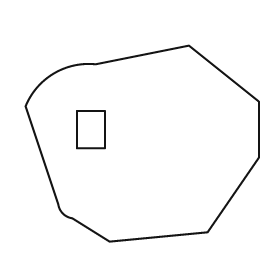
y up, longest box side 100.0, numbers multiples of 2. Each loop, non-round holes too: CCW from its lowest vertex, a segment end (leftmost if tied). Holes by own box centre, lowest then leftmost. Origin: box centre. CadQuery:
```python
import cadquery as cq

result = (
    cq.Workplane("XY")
    .moveTo(-14.0, -42.0)
    .lineTo(28.0, -38.0)
    .lineTo(50.0, -6.0)
    .lineTo(50.0, 18.0)
    .lineTo(20.0, 42.0)
    .lineTo(-20.0, 34.0)
    .threePointArc((-38.0, 30.0), (-50.0, 16.0))
    .lineTo(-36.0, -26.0)
    .threePointArc((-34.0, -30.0), (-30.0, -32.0))
    .close()
    .moveTo(-28.0, -2.0)
    .lineTo(-16.0, -2.0)
    .lineTo(-16.0, 14.0)
    .lineTo(-28.0, 14.0)
    .close()
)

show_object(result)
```